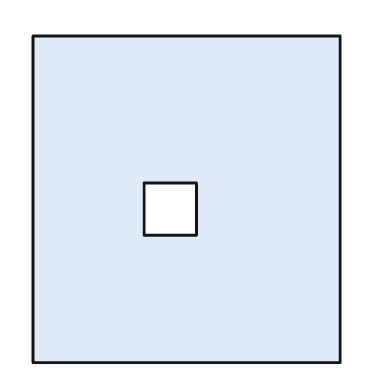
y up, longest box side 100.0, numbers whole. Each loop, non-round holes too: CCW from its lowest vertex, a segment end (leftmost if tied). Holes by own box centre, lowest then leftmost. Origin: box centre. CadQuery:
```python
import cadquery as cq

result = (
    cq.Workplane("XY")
    .moveTo(-47.0, -50.0)
    .lineTo(47.0, -50.0)
    .lineTo(47.0, 50.0)
    .lineTo(-47.0, 50.0)
    .close()
    .moveTo(-13.0, -11.0)
    .lineTo(3.0, -11.0)
    .lineTo(3.0, 5.0)
    .lineTo(-13.0, 5.0)
    .close()
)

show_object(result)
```